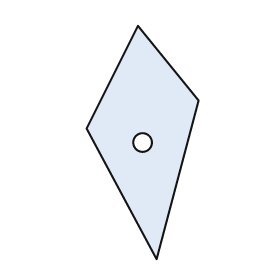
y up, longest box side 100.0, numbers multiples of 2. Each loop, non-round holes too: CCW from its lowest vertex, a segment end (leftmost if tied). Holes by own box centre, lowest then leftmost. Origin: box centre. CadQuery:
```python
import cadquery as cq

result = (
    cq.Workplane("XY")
    .moveTo(6.0, -50.0)
    .lineTo(24.0, 18.0)
    .lineTo(-2.0, 50.0)
    .lineTo(-24.0, 6.0)
    .close()
    .moveTo(0.0, 0.0)
    .circle(4.0)
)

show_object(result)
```